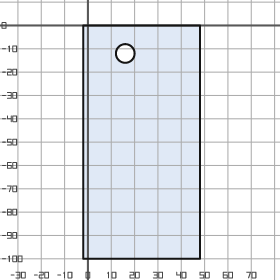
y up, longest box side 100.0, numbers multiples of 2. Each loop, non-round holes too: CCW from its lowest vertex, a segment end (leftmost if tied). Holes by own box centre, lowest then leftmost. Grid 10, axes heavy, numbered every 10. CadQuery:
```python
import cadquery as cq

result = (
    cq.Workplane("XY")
    .moveTo(-2.0, -100.0)
    .lineTo(48.0, -100.0)
    .lineTo(48.0, 0.0)
    .lineTo(-2.0, 0.0)
    .close()
    .moveTo(16.0, -12.0)
    .circle(4.0)
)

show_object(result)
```